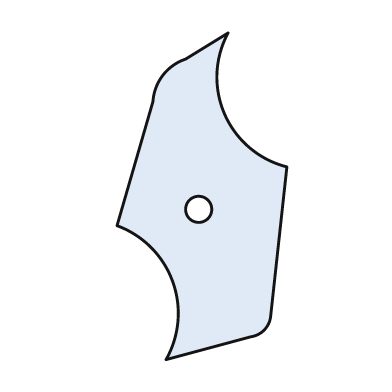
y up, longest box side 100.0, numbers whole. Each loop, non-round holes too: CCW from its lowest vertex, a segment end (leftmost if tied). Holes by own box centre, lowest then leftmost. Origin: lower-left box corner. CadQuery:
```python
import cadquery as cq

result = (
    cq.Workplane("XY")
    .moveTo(15.0, 0.0)
    .lineTo(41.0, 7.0)
    .threePointArc((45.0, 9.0), (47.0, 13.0))
    .lineTo(52.0, 59.0)
    .threePointArc((33.0, 75.0), (34.0, 100.0))
    .lineTo(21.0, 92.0)
    .threePointArc((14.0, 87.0), (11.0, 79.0))
    .lineTo(0.0, 41.0)
    .threePointArc((17.0, 24.0), (15.0, 0.0))
    .close()
    .moveTo(25.0, 46.0)
    .circle(4.0)
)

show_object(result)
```